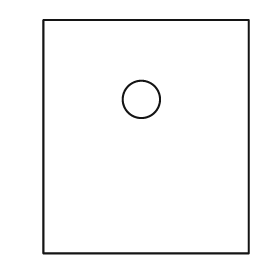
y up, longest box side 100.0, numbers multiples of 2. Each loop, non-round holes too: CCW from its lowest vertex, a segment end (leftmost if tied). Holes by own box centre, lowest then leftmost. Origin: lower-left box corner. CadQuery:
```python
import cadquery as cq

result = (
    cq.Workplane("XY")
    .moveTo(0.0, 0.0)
    .lineTo(88.0, 0.0)
    .lineTo(88.0, 100.0)
    .lineTo(0.0, 100.0)
    .close()
    .moveTo(42.0, 66.0)
    .circle(8.0)
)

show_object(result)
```